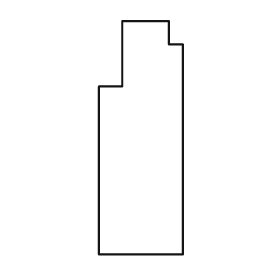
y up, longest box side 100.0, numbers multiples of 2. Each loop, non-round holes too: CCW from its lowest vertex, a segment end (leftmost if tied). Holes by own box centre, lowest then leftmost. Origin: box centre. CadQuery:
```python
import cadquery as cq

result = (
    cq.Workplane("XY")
    .moveTo(-18.0, -50.0)
    .lineTo(18.0, -50.0)
    .lineTo(18.0, 40.0)
    .lineTo(12.0, 40.0)
    .lineTo(12.0, 50.0)
    .lineTo(-8.0, 50.0)
    .lineTo(-8.0, 22.0)
    .lineTo(-18.0, 22.0)
    .close()
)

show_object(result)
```